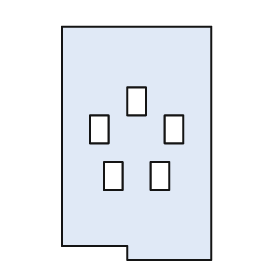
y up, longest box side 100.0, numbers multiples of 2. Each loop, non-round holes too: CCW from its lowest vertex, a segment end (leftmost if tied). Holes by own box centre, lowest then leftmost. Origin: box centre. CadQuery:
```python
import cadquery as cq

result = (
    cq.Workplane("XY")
    .moveTo(-4.0, -50.0)
    .lineTo(32.0, -50.0)
    .lineTo(32.0, 50.0)
    .lineTo(-32.0, 50.0)
    .lineTo(-32.0, -44.0)
    .lineTo(-4.0, -44.0)
    .close()
    .moveTo(-14.0, -20.0)
    .lineTo(-6.0, -20.0)
    .lineTo(-6.0, -8.0)
    .lineTo(-14.0, -8.0)
    .close()
    .moveTo(6.0, -20.0)
    .lineTo(14.0, -20.0)
    .lineTo(14.0, -8.0)
    .lineTo(6.0, -8.0)
    .close()
    .moveTo(-20.0, 0.0)
    .lineTo(-12.0, 0.0)
    .lineTo(-12.0, 12.0)
    .lineTo(-20.0, 12.0)
    .close()
    .moveTo(12.0, 0.0)
    .lineTo(20.0, 0.0)
    .lineTo(20.0, 12.0)
    .lineTo(12.0, 12.0)
    .close()
    .moveTo(-4.0, 12.0)
    .lineTo(4.0, 12.0)
    .lineTo(4.0, 24.0)
    .lineTo(-4.0, 24.0)
    .close()
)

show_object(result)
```